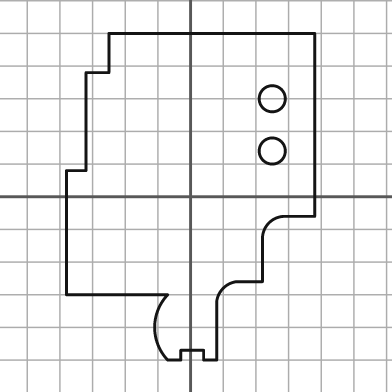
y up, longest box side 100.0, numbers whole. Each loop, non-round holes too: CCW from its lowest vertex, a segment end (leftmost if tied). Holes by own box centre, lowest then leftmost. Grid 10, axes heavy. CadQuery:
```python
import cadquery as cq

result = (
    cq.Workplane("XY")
    .moveTo(-7.0, -50.0)
    .lineTo(-3.0, -50.0)
    .lineTo(-3.0, -47.0)
    .lineTo(4.0, -47.0)
    .lineTo(4.0, -50.0)
    .lineTo(8.0, -50.0)
    .lineTo(8.0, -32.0)
    .threePointArc((10.0, -28.0), (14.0, -26.0))
    .lineTo(22.0, -26.0)
    .lineTo(22.0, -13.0)
    .threePointArc((24.0, -8.0), (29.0, -6.0))
    .lineTo(38.0, -6.0)
    .lineTo(38.0, 50.0)
    .lineTo(-25.0, 50.0)
    .lineTo(-25.0, 38.0)
    .lineTo(-32.0, 38.0)
    .lineTo(-32.0, 8.0)
    .lineTo(-38.0, 8.0)
    .lineTo(-38.0, -30.0)
    .lineTo(-7.0, -30.0)
    .threePointArc((-11.0, -40.0), (-7.0, -50.0))
    .close()
    .moveTo(25.0, 14.0)
    .circle(4.0)
    .moveTo(25.0, 30.0)
    .circle(4.0)
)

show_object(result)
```